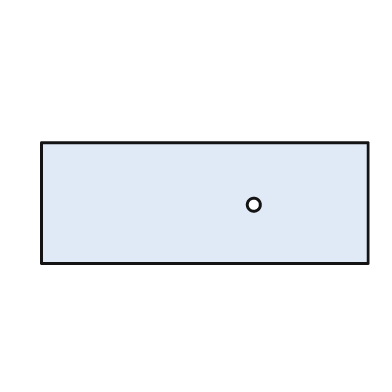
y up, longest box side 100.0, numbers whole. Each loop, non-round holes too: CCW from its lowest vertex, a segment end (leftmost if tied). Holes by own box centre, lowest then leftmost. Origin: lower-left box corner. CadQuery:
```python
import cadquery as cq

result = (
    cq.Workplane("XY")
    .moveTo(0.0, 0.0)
    .lineTo(100.0, 0.0)
    .lineTo(100.0, 37.0)
    .lineTo(0.0, 37.0)
    .close()
    .moveTo(65.0, 18.0)
    .circle(2.0)
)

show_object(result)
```